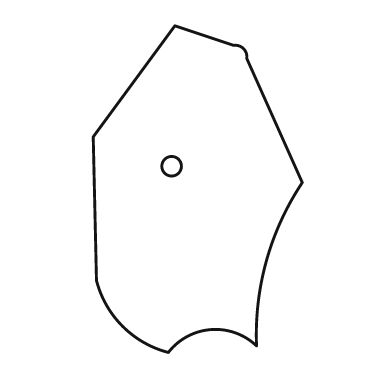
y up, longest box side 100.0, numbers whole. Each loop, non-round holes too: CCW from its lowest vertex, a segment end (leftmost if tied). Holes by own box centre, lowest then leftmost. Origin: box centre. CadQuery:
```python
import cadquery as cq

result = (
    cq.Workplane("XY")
    .moveTo(-9.0, -50.0)
    .threePointArc((4.0, -43.0), (18.0, -48.0))
    .threePointArc((21.0, -22.0), (32.0, 2.0))
    .lineTo(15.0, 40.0)
    .threePointArc((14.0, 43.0), (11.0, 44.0))
    .lineTo(-7.0, 50.0)
    .lineTo(-32.0, 16.0)
    .lineTo(-31.0, -28.0)
    .threePointArc((-23.0, -42.0), (-9.0, -50.0))
    .close()
    .moveTo(-8.0, 7.0)
    .circle(3.0)
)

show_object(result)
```